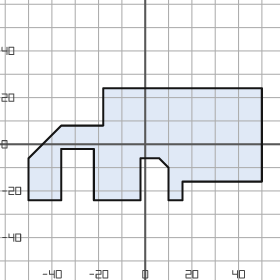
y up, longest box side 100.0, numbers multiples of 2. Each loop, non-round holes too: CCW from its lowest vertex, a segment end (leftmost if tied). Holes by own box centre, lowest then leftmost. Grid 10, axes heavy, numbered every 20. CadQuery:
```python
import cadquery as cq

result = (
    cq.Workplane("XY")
    .moveTo(-50.0, -24.0)
    .lineTo(-36.0, -24.0)
    .lineTo(-36.0, -2.0)
    .lineTo(-22.0, -2.0)
    .lineTo(-22.0, -24.0)
    .lineTo(-2.0, -24.0)
    .lineTo(-2.0, -6.0)
    .lineTo(6.0, -6.0)
    .lineTo(10.0, -10.0)
    .lineTo(10.0, -24.0)
    .lineTo(16.0, -24.0)
    .lineTo(16.0, -16.0)
    .lineTo(50.0, -16.0)
    .lineTo(50.0, 24.0)
    .lineTo(-18.0, 24.0)
    .lineTo(-18.0, 8.0)
    .lineTo(-36.0, 8.0)
    .lineTo(-50.0, -6.0)
    .close()
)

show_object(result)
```